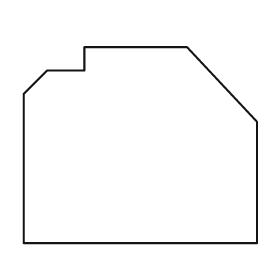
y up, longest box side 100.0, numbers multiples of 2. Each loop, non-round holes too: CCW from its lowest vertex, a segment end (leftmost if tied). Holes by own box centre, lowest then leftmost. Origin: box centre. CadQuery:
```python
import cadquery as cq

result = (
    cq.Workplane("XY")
    .moveTo(-50.0, -42.0)
    .lineTo(50.0, -42.0)
    .lineTo(50.0, 10.0)
    .lineTo(20.0, 42.0)
    .lineTo(-24.0, 42.0)
    .lineTo(-24.0, 32.0)
    .lineTo(-40.0, 32.0)
    .lineTo(-50.0, 22.0)
    .close()
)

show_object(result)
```